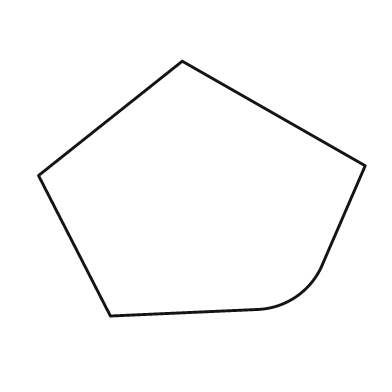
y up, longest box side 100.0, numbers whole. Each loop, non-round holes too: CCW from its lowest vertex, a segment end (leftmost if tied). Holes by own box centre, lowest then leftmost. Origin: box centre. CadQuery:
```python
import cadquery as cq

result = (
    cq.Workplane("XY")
    .moveTo(-28.0, -39.0)
    .lineTo(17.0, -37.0)
    .threePointArc((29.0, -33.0), (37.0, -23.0))
    .lineTo(50.0, 7.0)
    .lineTo(-6.0, 39.0)
    .lineTo(-50.0, 4.0)
    .close()
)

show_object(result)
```